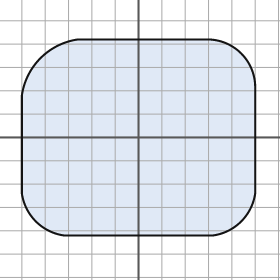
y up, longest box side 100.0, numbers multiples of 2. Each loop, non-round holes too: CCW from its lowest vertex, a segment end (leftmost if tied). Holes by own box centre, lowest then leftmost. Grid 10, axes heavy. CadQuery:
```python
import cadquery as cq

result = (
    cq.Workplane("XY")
    .moveTo(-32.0, -42.0)
    .lineTo(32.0, -42.0)
    .threePointArc((44.0, -36.0), (50.0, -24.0))
    .lineTo(50.0, 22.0)
    .threePointArc((44.0, 36.0), (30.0, 42.0))
    .lineTo(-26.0, 42.0)
    .threePointArc((-42.0, 34.0), (-50.0, 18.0))
    .lineTo(-50.0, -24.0)
    .threePointArc((-44.0, -36.0), (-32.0, -42.0))
    .close()
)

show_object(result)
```